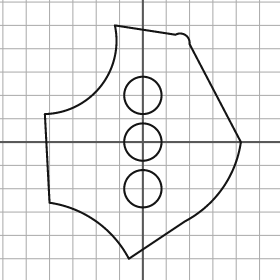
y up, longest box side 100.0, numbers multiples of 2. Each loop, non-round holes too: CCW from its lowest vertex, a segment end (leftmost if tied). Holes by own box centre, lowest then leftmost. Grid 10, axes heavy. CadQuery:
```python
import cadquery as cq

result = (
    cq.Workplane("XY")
    .moveTo(-6.0, -50.0)
    .lineTo(18.0, -34.0)
    .threePointArc((34.0, -20.0), (42.0, 0.0))
    .lineTo(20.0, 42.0)
    .threePointArc((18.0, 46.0), (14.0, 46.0))
    .lineTo(-12.0, 50.0)
    .threePointArc((-18.0, 24.0), (-42.0, 12.0))
    .lineTo(-40.0, -26.0)
    .threePointArc((-20.0, -34.0), (-6.0, -50.0))
    .close()
    .moveTo(0.0, -20.0)
    .circle(8.0)
    .moveTo(0.0, 0.0)
    .circle(8.0)
    .moveTo(0.0, 20.0)
    .circle(8.0)
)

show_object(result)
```